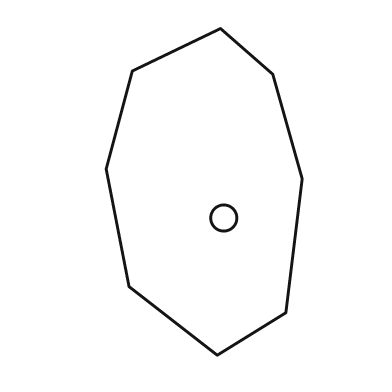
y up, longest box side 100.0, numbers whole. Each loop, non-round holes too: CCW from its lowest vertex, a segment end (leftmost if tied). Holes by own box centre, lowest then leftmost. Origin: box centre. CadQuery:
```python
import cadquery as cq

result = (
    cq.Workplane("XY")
    .moveTo(4.0, -50.0)
    .lineTo(25.0, -37.0)
    .lineTo(30.0, 4.0)
    .lineTo(21.0, 36.0)
    .lineTo(5.0, 50.0)
    .lineTo(-22.0, 37.0)
    .lineTo(-30.0, 7.0)
    .lineTo(-23.0, -29.0)
    .close()
    .moveTo(6.0, -8.0)
    .circle(4.0)
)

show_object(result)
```